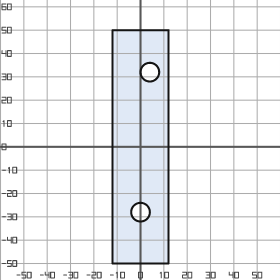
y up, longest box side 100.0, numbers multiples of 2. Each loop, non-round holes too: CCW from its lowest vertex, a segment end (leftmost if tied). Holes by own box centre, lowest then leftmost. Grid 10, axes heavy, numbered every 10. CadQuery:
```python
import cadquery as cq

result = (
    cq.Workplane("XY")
    .moveTo(-12.0, -50.0)
    .lineTo(12.0, -50.0)
    .lineTo(12.0, 50.0)
    .lineTo(-12.0, 50.0)
    .close()
    .moveTo(0.0, -28.0)
    .circle(4.0)
    .moveTo(4.0, 32.0)
    .circle(4.0)
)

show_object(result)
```